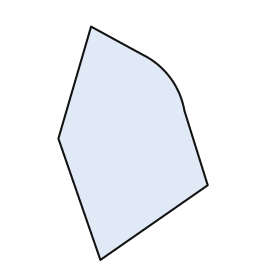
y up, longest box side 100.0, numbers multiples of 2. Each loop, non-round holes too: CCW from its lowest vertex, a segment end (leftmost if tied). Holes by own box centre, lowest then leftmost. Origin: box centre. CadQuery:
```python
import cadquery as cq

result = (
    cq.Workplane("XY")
    .moveTo(-14.0, -50.0)
    .lineTo(32.0, -18.0)
    .lineTo(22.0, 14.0)
    .threePointArc((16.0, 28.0), (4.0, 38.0))
    .lineTo(-18.0, 50.0)
    .lineTo(-32.0, 2.0)
    .close()
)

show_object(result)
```